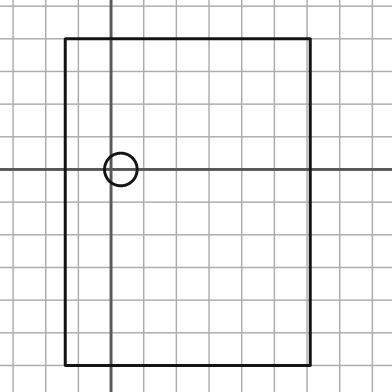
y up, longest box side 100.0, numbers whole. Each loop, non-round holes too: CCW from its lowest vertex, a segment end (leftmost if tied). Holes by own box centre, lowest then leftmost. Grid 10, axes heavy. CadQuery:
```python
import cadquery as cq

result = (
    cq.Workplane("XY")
    .moveTo(-14.0, -60.0)
    .lineTo(61.0, -60.0)
    .lineTo(61.0, 40.0)
    .lineTo(-14.0, 40.0)
    .close()
    .moveTo(3.0, 0.0)
    .circle(5.0)
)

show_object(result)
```